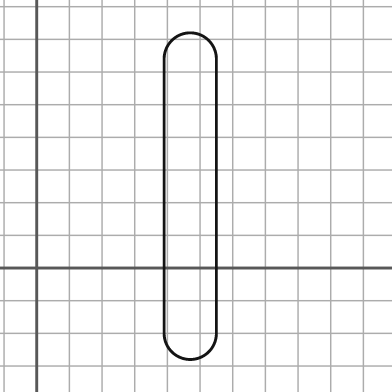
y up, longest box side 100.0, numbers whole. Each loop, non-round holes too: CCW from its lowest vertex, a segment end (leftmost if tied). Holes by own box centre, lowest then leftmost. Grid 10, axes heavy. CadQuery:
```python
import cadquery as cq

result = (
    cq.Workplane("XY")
    .moveTo(39.0, -20.0)
    .threePointArc((47.0, -28.0), (55.0, -20.0))
    .lineTo(55.0, 64.0)
    .threePointArc((47.0, 72.0), (39.0, 64.0))
    .close()
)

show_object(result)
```